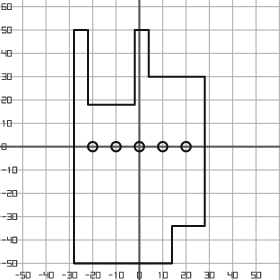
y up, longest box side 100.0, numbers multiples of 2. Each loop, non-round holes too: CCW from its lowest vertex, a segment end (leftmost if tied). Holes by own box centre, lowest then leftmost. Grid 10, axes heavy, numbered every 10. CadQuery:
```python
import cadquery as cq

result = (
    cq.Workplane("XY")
    .moveTo(-28.0, -50.0)
    .lineTo(14.0, -50.0)
    .lineTo(14.0, -34.0)
    .lineTo(28.0, -34.0)
    .lineTo(28.0, 30.0)
    .lineTo(4.0, 30.0)
    .lineTo(4.0, 50.0)
    .lineTo(-2.0, 50.0)
    .lineTo(-2.0, 18.0)
    .lineTo(-22.0, 18.0)
    .lineTo(-22.0, 50.0)
    .lineTo(-28.0, 50.0)
    .close()
    .moveTo(-20.0, 0.0)
    .circle(2.0)
    .moveTo(-10.0, 0.0)
    .circle(2.0)
    .moveTo(0.0, 0.0)
    .circle(2.0)
    .moveTo(10.0, 0.0)
    .circle(2.0)
    .moveTo(20.0, 0.0)
    .circle(2.0)
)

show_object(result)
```